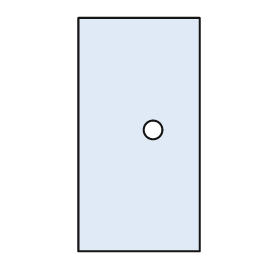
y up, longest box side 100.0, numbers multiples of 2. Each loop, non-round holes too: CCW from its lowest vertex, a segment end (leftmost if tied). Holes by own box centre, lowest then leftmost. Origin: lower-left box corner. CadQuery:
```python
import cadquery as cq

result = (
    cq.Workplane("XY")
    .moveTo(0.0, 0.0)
    .lineTo(52.0, 0.0)
    .lineTo(52.0, 100.0)
    .lineTo(0.0, 100.0)
    .close()
    .moveTo(32.0, 52.0)
    .circle(4.0)
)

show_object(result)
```